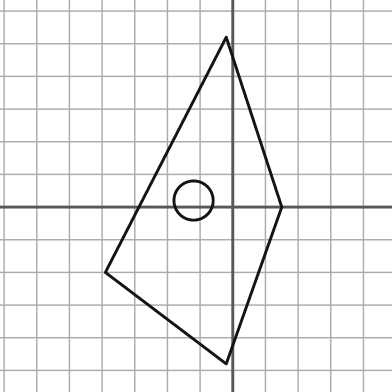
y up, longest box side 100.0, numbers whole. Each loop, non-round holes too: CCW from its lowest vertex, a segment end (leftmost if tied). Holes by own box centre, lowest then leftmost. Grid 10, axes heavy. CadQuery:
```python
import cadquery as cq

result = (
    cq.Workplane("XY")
    .moveTo(-2.0, -48.0)
    .lineTo(15.0, 0.0)
    .lineTo(-2.0, 52.0)
    .lineTo(-39.0, -20.0)
    .close()
    .moveTo(-12.0, 2.0)
    .circle(6.0)
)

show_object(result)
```